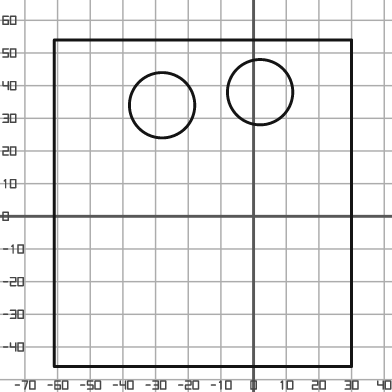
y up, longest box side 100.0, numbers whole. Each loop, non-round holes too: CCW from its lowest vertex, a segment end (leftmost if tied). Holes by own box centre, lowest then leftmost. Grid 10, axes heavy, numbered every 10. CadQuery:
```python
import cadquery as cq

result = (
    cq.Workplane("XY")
    .moveTo(-61.0, -46.0)
    .lineTo(30.0, -46.0)
    .lineTo(30.0, 54.0)
    .lineTo(-61.0, 54.0)
    .close()
    .moveTo(-28.0, 34.0)
    .circle(10.0)
    .moveTo(2.0, 38.0)
    .circle(10.0)
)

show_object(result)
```